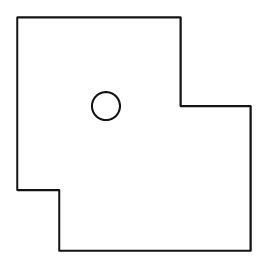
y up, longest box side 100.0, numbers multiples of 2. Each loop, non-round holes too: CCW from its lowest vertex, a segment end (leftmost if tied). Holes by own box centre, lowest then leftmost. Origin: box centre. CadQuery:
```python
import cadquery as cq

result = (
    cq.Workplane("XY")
    .moveTo(-32.0, -50.0)
    .lineTo(50.0, -50.0)
    .lineTo(50.0, 12.0)
    .lineTo(20.0, 12.0)
    .lineTo(20.0, 50.0)
    .lineTo(-50.0, 50.0)
    .lineTo(-50.0, -24.0)
    .lineTo(-32.0, -24.0)
    .close()
    .moveTo(-12.0, 12.0)
    .circle(6.0)
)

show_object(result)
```